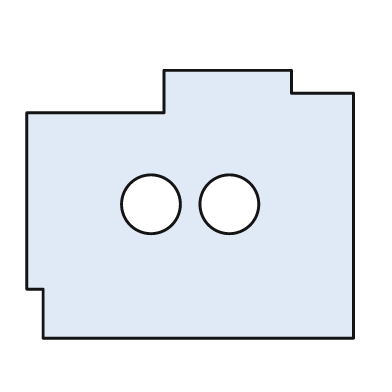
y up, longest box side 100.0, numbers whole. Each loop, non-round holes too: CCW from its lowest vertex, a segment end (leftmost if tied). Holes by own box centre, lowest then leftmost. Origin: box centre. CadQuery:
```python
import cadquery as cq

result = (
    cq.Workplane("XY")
    .moveTo(-45.0, -41.0)
    .lineTo(50.0, -41.0)
    .lineTo(50.0, 34.0)
    .lineTo(31.0, 34.0)
    .lineTo(31.0, 41.0)
    .lineTo(-8.0, 41.0)
    .lineTo(-8.0, 28.0)
    .lineTo(-50.0, 28.0)
    .lineTo(-50.0, -26.0)
    .lineTo(-45.0, -26.0)
    .close()
    .moveTo(-12.0, 0.0)
    .circle(9.0)
    .moveTo(12.0, 0.0)
    .circle(9.0)
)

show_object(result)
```